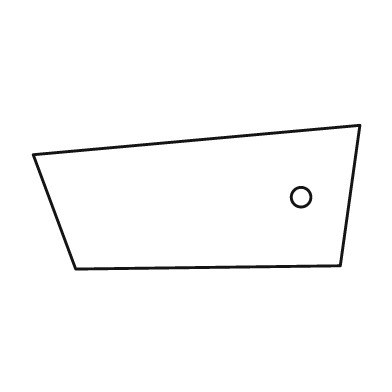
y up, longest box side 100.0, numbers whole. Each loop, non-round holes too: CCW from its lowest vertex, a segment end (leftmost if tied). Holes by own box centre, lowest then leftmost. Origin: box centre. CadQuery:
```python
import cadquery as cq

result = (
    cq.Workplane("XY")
    .moveTo(-37.0, -22.0)
    .lineTo(44.0, -21.0)
    .lineTo(50.0, 22.0)
    .lineTo(-50.0, 13.0)
    .close()
    .moveTo(32.0, 0.0)
    .circle(3.0)
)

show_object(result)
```